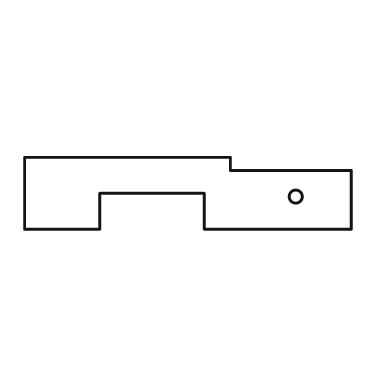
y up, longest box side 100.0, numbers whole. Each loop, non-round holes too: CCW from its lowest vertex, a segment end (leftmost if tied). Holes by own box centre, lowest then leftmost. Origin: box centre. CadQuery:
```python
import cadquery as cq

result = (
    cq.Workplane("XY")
    .moveTo(-50.0, -11.0)
    .lineTo(-27.0, -11.0)
    .lineTo(-27.0, 0.0)
    .lineTo(5.0, 0.0)
    .lineTo(5.0, -11.0)
    .lineTo(50.0, -11.0)
    .lineTo(50.0, 7.0)
    .lineTo(13.0, 7.0)
    .lineTo(13.0, 11.0)
    .lineTo(-50.0, 11.0)
    .close()
    .moveTo(33.0, -1.0)
    .circle(2.0)
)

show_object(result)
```